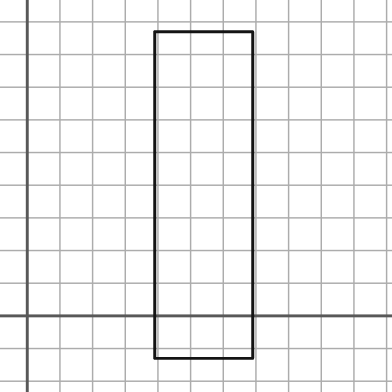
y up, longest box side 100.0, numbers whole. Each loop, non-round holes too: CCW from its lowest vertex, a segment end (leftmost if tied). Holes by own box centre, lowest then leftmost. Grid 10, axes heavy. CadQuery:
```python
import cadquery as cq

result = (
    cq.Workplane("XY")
    .moveTo(39.0, -13.0)
    .lineTo(69.0, -13.0)
    .lineTo(69.0, 87.0)
    .lineTo(39.0, 87.0)
    .close()
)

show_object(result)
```